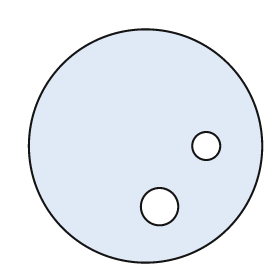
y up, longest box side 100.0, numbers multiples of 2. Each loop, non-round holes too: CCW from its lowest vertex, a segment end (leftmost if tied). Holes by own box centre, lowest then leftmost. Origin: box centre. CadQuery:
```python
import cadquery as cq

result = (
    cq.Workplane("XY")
    .moveTo(0.0, 0.0)
    .circle(50.0)
    .moveTo(6.0, -26.0)
    .circle(8.0)
    .moveTo(26.0, 0.0)
    .circle(6.0)
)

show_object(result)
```